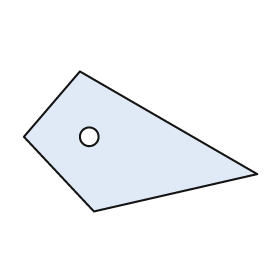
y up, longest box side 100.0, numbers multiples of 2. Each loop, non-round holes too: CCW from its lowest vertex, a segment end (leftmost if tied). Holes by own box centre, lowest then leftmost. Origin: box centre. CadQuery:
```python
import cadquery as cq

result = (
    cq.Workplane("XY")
    .moveTo(-20.0, -30.0)
    .lineTo(50.0, -14.0)
    .lineTo(-26.0, 30.0)
    .lineTo(-50.0, 2.0)
    .close()
    .moveTo(-22.0, 2.0)
    .circle(4.0)
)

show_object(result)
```